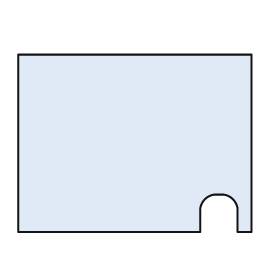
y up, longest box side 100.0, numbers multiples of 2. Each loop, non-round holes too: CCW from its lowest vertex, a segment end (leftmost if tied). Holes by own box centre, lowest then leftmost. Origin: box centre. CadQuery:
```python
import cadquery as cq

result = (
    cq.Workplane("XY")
    .moveTo(-50.0, -38.0)
    .lineTo(28.0, -38.0)
    .lineTo(28.0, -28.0)
    .threePointArc((30.0, -24.0), (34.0, -22.0))
    .lineTo(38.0, -22.0)
    .threePointArc((42.0, -24.0), (44.0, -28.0))
    .lineTo(44.0, -38.0)
    .lineTo(50.0, -38.0)
    .lineTo(50.0, 38.0)
    .lineTo(-50.0, 38.0)
    .close()
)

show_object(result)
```